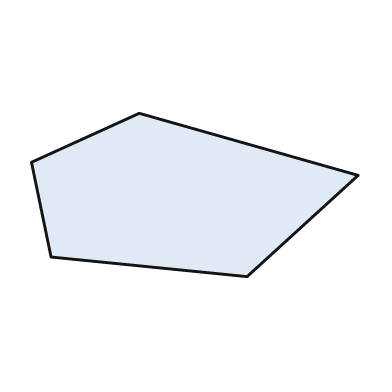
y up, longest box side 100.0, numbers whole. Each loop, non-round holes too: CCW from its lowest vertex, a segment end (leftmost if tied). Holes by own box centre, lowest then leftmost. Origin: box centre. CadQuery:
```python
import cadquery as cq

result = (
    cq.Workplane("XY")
    .moveTo(16.0, -25.0)
    .lineTo(50.0, 6.0)
    .lineTo(-17.0, 25.0)
    .lineTo(-50.0, 10.0)
    .lineTo(-44.0, -19.0)
    .close()
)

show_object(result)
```